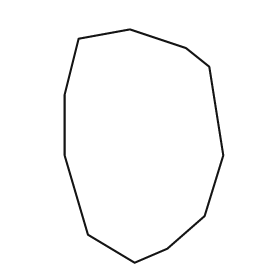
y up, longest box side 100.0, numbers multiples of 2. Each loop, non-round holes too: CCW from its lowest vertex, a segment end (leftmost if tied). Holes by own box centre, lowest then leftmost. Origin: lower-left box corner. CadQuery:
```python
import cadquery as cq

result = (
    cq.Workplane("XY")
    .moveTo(30.0, 0.0)
    .lineTo(44.0, 6.0)
    .lineTo(60.0, 20.0)
    .lineTo(68.0, 46.0)
    .lineTo(62.0, 84.0)
    .lineTo(52.0, 92.0)
    .lineTo(28.0, 100.0)
    .lineTo(6.0, 96.0)
    .lineTo(0.0, 72.0)
    .lineTo(0.0, 46.0)
    .lineTo(10.0, 12.0)
    .close()
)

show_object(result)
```